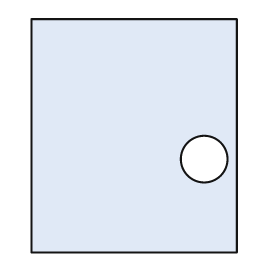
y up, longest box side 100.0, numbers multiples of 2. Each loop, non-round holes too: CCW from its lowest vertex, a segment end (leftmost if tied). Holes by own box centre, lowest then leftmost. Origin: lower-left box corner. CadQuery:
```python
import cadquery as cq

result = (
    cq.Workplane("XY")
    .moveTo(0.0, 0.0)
    .lineTo(88.0, 0.0)
    .lineTo(88.0, 100.0)
    .lineTo(0.0, 100.0)
    .close()
    .moveTo(74.0, 40.0)
    .circle(10.0)
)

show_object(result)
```